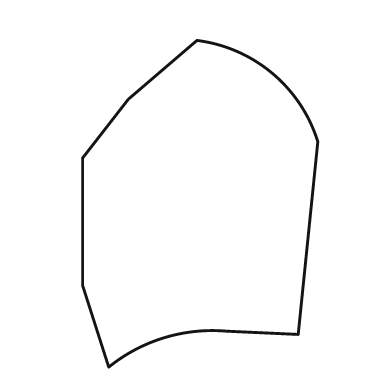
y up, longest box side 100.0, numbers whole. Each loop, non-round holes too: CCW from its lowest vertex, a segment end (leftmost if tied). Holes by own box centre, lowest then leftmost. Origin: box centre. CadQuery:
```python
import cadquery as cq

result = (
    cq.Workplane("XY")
    .moveTo(-28.0, -50.0)
    .threePointArc((-11.0, -41.0), (8.0, -39.0))
    .lineTo(30.0, -40.0)
    .lineTo(36.0, 19.0)
    .threePointArc((22.0, 40.0), (-1.0, 50.0))
    .lineTo(-22.0, 32.0)
    .lineTo(-36.0, 14.0)
    .lineTo(-36.0, -25.0)
    .close()
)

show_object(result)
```